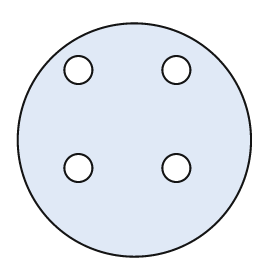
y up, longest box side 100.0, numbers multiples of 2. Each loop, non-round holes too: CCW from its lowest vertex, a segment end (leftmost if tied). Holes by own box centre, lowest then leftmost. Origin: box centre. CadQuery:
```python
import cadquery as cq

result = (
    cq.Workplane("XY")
    .moveTo(0.0, 0.0)
    .circle(50.0)
    .moveTo(-24.0, -12.0)
    .circle(6.0)
    .moveTo(18.0, -12.0)
    .circle(6.0)
    .moveTo(-24.0, 30.0)
    .circle(6.0)
    .moveTo(18.0, 30.0)
    .circle(6.0)
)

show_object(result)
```